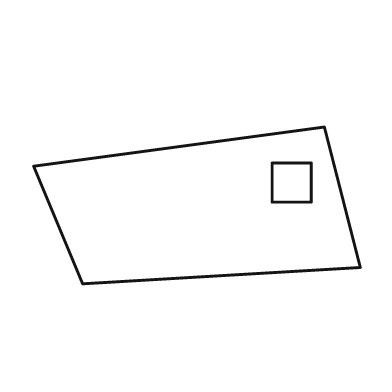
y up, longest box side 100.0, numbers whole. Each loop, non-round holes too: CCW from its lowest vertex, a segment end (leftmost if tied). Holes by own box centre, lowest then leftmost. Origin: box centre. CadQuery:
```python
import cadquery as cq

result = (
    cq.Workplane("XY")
    .moveTo(-35.0, -24.0)
    .lineTo(50.0, -19.0)
    .lineTo(39.0, 24.0)
    .lineTo(-50.0, 12.0)
    .close()
    .moveTo(23.0, 1.0)
    .lineTo(35.0, 1.0)
    .lineTo(35.0, 13.0)
    .lineTo(23.0, 13.0)
    .close()
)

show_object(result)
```